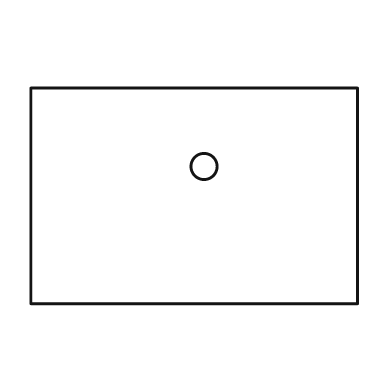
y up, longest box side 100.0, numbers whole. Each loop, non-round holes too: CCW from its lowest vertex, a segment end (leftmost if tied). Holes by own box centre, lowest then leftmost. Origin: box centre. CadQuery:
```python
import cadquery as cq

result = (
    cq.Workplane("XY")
    .moveTo(-50.0, -33.0)
    .lineTo(50.0, -33.0)
    .lineTo(50.0, 33.0)
    .lineTo(-50.0, 33.0)
    .close()
    .moveTo(3.0, 9.0)
    .circle(4.0)
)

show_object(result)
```